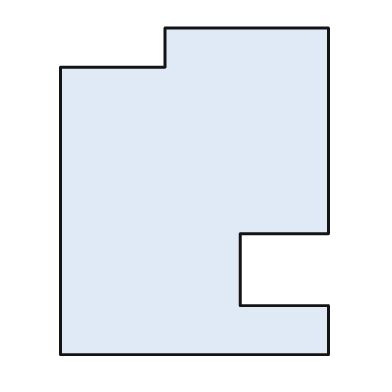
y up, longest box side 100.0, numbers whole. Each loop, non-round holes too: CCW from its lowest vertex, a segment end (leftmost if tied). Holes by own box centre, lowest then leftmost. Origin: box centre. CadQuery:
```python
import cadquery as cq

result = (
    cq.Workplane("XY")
    .moveTo(-41.0, -50.0)
    .lineTo(41.0, -50.0)
    .lineTo(41.0, -35.0)
    .lineTo(14.0, -35.0)
    .lineTo(14.0, -13.0)
    .lineTo(41.0, -13.0)
    .lineTo(41.0, 50.0)
    .lineTo(-9.0, 50.0)
    .lineTo(-9.0, 38.0)
    .lineTo(-41.0, 38.0)
    .close()
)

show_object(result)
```